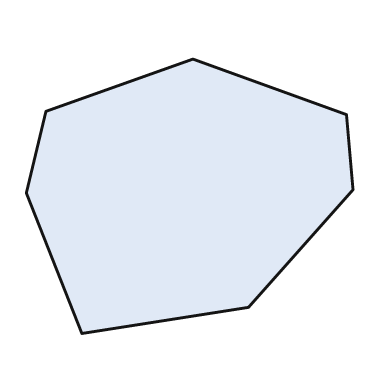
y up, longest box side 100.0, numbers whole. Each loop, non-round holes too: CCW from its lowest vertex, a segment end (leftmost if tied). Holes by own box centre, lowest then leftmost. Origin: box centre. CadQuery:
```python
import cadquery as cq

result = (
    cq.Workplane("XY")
    .moveTo(-33.0, -42.0)
    .lineTo(18.0, -34.0)
    .lineTo(50.0, 2.0)
    .lineTo(48.0, 25.0)
    .lineTo(1.0, 42.0)
    .lineTo(-44.0, 26.0)
    .lineTo(-50.0, 1.0)
    .close()
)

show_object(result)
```